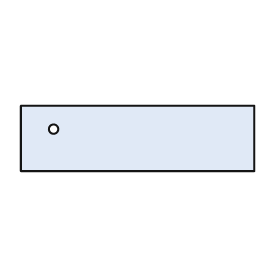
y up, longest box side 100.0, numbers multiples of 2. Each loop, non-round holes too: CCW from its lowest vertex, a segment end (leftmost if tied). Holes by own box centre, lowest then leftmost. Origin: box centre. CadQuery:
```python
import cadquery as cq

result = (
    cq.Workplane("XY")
    .moveTo(-50.0, -14.0)
    .lineTo(50.0, -14.0)
    .lineTo(50.0, 14.0)
    .lineTo(-50.0, 14.0)
    .close()
    .moveTo(-36.0, 4.0)
    .circle(2.0)
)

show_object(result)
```